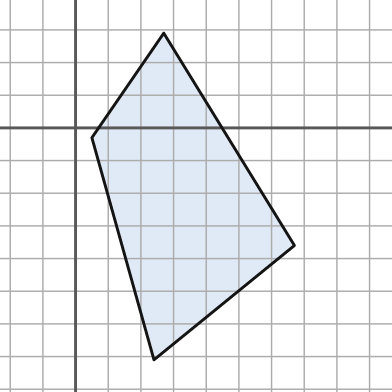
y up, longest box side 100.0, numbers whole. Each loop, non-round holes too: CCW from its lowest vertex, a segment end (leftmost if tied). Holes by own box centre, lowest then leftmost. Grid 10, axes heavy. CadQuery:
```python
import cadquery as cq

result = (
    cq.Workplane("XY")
    .moveTo(24.0, -71.0)
    .lineTo(67.0, -36.0)
    .lineTo(27.0, 29.0)
    .lineTo(5.0, -3.0)
    .close()
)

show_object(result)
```